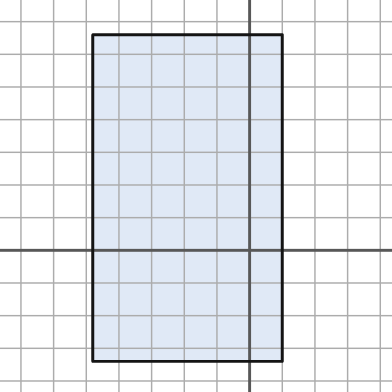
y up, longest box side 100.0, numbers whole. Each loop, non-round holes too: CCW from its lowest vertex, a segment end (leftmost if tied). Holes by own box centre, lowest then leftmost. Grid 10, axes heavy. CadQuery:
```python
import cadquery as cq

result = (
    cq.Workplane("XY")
    .moveTo(-48.0, -34.0)
    .lineTo(10.0, -34.0)
    .lineTo(10.0, 66.0)
    .lineTo(-48.0, 66.0)
    .close()
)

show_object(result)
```